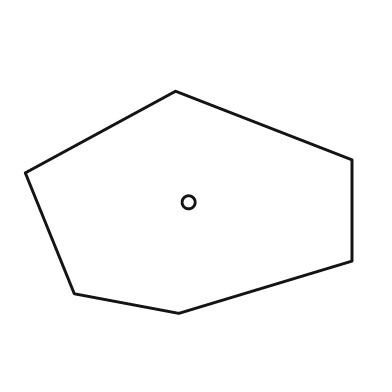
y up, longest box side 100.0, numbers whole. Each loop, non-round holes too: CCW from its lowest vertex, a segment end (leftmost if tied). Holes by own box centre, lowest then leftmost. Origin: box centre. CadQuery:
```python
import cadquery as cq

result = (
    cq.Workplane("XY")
    .moveTo(-3.0, -34.0)
    .lineTo(50.0, -18.0)
    .lineTo(50.0, 13.0)
    .lineTo(-4.0, 34.0)
    .lineTo(-50.0, 9.0)
    .lineTo(-35.0, -28.0)
    .close()
    .moveTo(0.0, 0.0)
    .circle(2.0)
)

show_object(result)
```